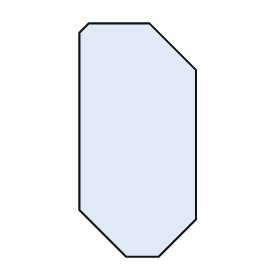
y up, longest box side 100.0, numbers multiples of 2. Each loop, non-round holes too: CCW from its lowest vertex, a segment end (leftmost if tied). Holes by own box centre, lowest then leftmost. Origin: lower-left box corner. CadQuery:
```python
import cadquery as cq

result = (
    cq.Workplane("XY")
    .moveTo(20.0, 0.0)
    .lineTo(34.0, 0.0)
    .lineTo(50.0, 16.0)
    .lineTo(50.0, 80.0)
    .lineTo(30.0, 100.0)
    .lineTo(4.0, 100.0)
    .lineTo(0.0, 96.0)
    .lineTo(0.0, 20.0)
    .close()
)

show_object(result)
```